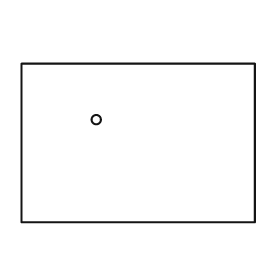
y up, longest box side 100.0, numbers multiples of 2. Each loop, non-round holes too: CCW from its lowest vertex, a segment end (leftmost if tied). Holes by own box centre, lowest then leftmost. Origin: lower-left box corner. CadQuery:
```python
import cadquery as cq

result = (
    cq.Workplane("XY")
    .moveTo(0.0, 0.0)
    .lineTo(100.0, 0.0)
    .lineTo(100.0, 68.0)
    .lineTo(0.0, 68.0)
    .close()
    .moveTo(32.0, 44.0)
    .circle(2.0)
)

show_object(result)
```